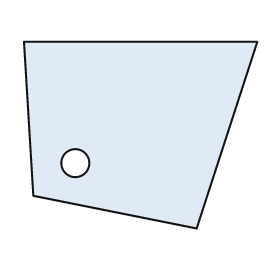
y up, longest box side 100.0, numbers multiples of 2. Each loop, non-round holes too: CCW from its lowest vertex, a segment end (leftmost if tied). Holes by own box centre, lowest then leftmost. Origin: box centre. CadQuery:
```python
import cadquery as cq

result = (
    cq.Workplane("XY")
    .moveTo(24.0, -40.0)
    .lineTo(50.0, 40.0)
    .lineTo(-50.0, 40.0)
    .lineTo(-46.0, -26.0)
    .close()
    .moveTo(-28.0, -12.0)
    .circle(6.0)
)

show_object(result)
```